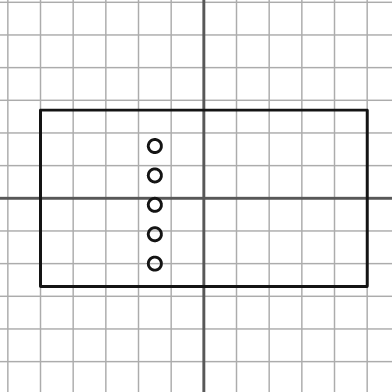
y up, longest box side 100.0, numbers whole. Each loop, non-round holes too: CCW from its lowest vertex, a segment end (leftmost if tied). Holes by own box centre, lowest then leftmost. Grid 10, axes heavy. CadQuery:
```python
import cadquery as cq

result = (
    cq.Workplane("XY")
    .moveTo(-50.0, -27.0)
    .lineTo(50.0, -27.0)
    .lineTo(50.0, 27.0)
    .lineTo(-50.0, 27.0)
    .close()
    .moveTo(-15.0, -20.0)
    .circle(2.0)
    .moveTo(-15.0, -11.0)
    .circle(2.0)
    .moveTo(-15.0, -2.0)
    .circle(2.0)
    .moveTo(-15.0, 7.0)
    .circle(2.0)
    .moveTo(-15.0, 16.0)
    .circle(2.0)
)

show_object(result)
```